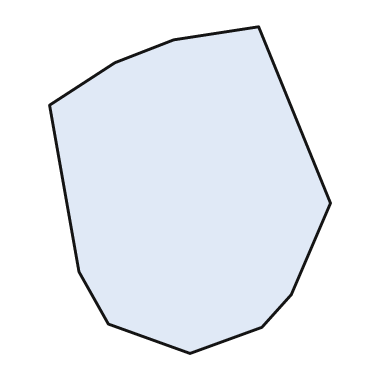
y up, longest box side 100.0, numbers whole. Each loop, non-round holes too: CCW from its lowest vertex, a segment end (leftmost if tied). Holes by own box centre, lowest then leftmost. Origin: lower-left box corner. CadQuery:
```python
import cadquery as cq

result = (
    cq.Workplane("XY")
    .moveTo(43.0, 0.0)
    .lineTo(65.0, 8.0)
    .lineTo(74.0, 18.0)
    .lineTo(86.0, 46.0)
    .lineTo(64.0, 100.0)
    .lineTo(38.0, 96.0)
    .lineTo(20.0, 89.0)
    .lineTo(0.0, 76.0)
    .lineTo(9.0, 25.0)
    .lineTo(18.0, 9.0)
    .close()
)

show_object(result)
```